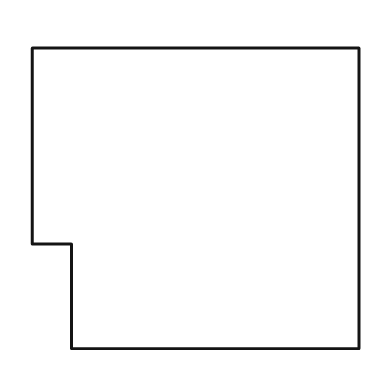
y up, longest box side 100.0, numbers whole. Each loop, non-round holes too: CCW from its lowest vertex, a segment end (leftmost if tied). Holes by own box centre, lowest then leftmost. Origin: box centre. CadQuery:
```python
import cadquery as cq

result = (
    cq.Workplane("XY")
    .moveTo(-38.0, -46.0)
    .lineTo(50.0, -46.0)
    .lineTo(50.0, 46.0)
    .lineTo(-50.0, 46.0)
    .lineTo(-50.0, -14.0)
    .lineTo(-38.0, -14.0)
    .close()
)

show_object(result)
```